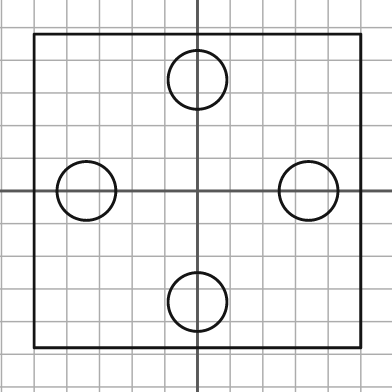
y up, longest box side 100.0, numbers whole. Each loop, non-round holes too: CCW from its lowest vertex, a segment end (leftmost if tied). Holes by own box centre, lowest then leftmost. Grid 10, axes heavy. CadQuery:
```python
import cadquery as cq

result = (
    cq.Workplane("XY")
    .moveTo(-50.0, -48.0)
    .lineTo(50.0, -48.0)
    .lineTo(50.0, 48.0)
    .lineTo(-50.0, 48.0)
    .close()
    .moveTo(0.0, -34.0)
    .circle(9.0)
    .moveTo(-34.0, 0.0)
    .circle(9.0)
    .moveTo(34.0, 0.0)
    .circle(9.0)
    .moveTo(0.0, 34.0)
    .circle(9.0)
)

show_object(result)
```